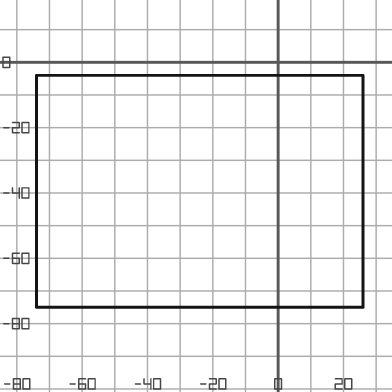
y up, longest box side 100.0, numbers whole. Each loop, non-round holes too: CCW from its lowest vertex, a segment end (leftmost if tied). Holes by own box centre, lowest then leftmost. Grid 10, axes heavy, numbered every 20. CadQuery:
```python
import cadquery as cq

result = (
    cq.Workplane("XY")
    .moveTo(-74.0, -75.0)
    .lineTo(26.0, -75.0)
    .lineTo(26.0, -4.0)
    .lineTo(-74.0, -4.0)
    .close()
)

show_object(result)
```